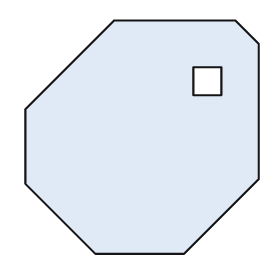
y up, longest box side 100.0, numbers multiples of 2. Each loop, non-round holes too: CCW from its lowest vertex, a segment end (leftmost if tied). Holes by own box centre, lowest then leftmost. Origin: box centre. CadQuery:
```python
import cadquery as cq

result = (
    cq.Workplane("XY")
    .moveTo(-20.0, -50.0)
    .lineTo(18.0, -50.0)
    .lineTo(50.0, -18.0)
    .lineTo(50.0, 40.0)
    .lineTo(40.0, 50.0)
    .lineTo(-12.0, 50.0)
    .lineTo(-50.0, 12.0)
    .lineTo(-50.0, -20.0)
    .close()
    .moveTo(22.0, 18.0)
    .lineTo(34.0, 18.0)
    .lineTo(34.0, 30.0)
    .lineTo(22.0, 30.0)
    .close()
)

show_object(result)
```